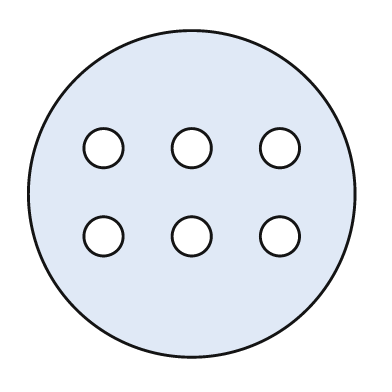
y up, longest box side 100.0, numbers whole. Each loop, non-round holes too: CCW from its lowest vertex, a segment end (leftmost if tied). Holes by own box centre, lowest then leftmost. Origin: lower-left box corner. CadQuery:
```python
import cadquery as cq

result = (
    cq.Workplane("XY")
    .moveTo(50.0, 50.0)
    .circle(50.0)
    .moveTo(23.0, 37.0)
    .circle(6.0)
    .moveTo(50.0, 37.0)
    .circle(6.0)
    .moveTo(77.0, 37.0)
    .circle(6.0)
    .moveTo(23.0, 64.0)
    .circle(6.0)
    .moveTo(50.0, 64.0)
    .circle(6.0)
    .moveTo(77.0, 64.0)
    .circle(6.0)
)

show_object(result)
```